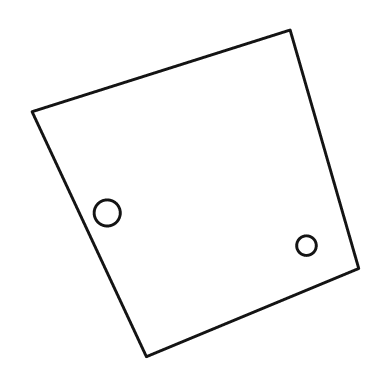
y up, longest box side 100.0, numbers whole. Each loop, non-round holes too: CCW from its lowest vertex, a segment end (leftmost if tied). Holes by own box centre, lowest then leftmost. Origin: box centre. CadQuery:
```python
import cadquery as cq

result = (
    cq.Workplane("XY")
    .moveTo(-15.0, -50.0)
    .lineTo(50.0, -23.0)
    .lineTo(29.0, 50.0)
    .lineTo(-50.0, 25.0)
    .close()
    .moveTo(34.0, -16.0)
    .circle(3.0)
    .moveTo(-27.0, -6.0)
    .circle(4.0)
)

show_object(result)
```